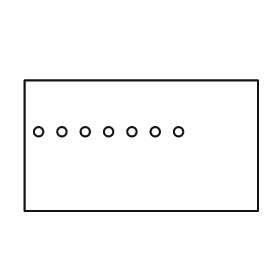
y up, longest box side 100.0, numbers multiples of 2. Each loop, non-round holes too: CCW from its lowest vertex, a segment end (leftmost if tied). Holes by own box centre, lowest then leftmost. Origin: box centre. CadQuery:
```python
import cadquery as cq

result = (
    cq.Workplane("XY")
    .moveTo(-50.0, -28.0)
    .lineTo(50.0, -28.0)
    .lineTo(50.0, 28.0)
    .lineTo(-50.0, 28.0)
    .close()
    .moveTo(-44.0, 6.0)
    .circle(2.0)
    .moveTo(-34.0, 6.0)
    .circle(2.0)
    .moveTo(-24.0, 6.0)
    .circle(2.0)
    .moveTo(-14.0, 6.0)
    .circle(2.0)
    .moveTo(-4.0, 6.0)
    .circle(2.0)
    .moveTo(6.0, 6.0)
    .circle(2.0)
    .moveTo(16.0, 6.0)
    .circle(2.0)
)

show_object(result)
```